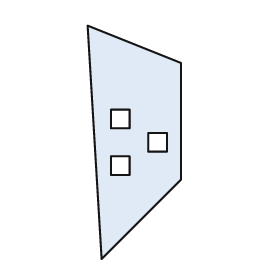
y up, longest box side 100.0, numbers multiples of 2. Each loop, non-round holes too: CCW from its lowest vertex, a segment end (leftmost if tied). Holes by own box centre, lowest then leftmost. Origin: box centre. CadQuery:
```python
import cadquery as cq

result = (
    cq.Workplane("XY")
    .moveTo(-14.0, -50.0)
    .lineTo(20.0, -16.0)
    .lineTo(20.0, 34.0)
    .lineTo(-20.0, 50.0)
    .close()
    .moveTo(-10.0, -14.0)
    .lineTo(-2.0, -14.0)
    .lineTo(-2.0, -6.0)
    .lineTo(-10.0, -6.0)
    .close()
    .moveTo(6.0, -4.0)
    .lineTo(14.0, -4.0)
    .lineTo(14.0, 4.0)
    .lineTo(6.0, 4.0)
    .close()
    .moveTo(-10.0, 6.0)
    .lineTo(-2.0, 6.0)
    .lineTo(-2.0, 14.0)
    .lineTo(-10.0, 14.0)
    .close()
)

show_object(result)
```